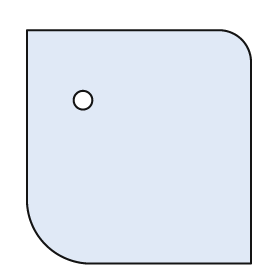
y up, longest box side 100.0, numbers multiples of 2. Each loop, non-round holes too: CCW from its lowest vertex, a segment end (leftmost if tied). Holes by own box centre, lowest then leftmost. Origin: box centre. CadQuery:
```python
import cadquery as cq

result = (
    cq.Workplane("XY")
    .moveTo(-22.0, -50.0)
    .lineTo(48.0, -50.0)
    .lineTo(48.0, 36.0)
    .threePointArc((44.0, 46.0), (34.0, 50.0))
    .lineTo(-48.0, 50.0)
    .lineTo(-48.0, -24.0)
    .threePointArc((-40.0, -42.0), (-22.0, -50.0))
    .close()
    .moveTo(-24.0, 20.0)
    .circle(4.0)
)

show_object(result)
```